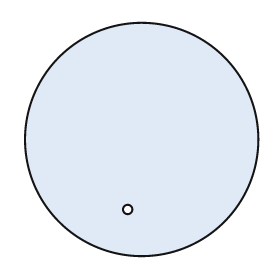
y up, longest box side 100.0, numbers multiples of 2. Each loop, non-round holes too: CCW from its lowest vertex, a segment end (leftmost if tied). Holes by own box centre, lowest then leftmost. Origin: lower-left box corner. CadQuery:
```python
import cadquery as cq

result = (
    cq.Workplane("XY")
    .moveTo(50.0, 50.0)
    .circle(50.0)
    .moveTo(44.0, 20.0)
    .circle(2.0)
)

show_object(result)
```